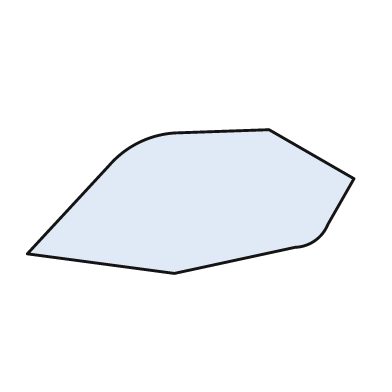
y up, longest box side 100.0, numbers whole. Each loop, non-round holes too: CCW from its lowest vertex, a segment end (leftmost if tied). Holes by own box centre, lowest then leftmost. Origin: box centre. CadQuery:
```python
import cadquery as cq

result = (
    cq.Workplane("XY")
    .moveTo(-5.0, -22.0)
    .lineTo(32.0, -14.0)
    .threePointArc((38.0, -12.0), (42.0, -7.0))
    .lineTo(50.0, 7.0)
    .lineTo(24.0, 22.0)
    .lineTo(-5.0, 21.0)
    .threePointArc((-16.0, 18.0), (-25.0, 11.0))
    .lineTo(-50.0, -16.0)
    .close()
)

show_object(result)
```